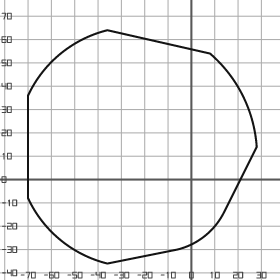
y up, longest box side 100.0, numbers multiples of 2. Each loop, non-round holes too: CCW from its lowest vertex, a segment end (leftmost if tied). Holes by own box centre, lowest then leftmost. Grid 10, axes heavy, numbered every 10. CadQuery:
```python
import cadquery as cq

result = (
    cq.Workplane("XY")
    .moveTo(-36.0, -36.0)
    .lineTo(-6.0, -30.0)
    .threePointArc((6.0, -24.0), (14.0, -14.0))
    .lineTo(28.0, 14.0)
    .threePointArc((22.0, 36.0), (8.0, 54.0))
    .lineTo(-36.0, 64.0)
    .threePointArc((-56.0, 54.0), (-70.0, 36.0))
    .lineTo(-70.0, -8.0)
    .threePointArc((-56.0, -26.0), (-36.0, -36.0))
    .close()
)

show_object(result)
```